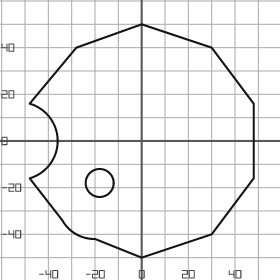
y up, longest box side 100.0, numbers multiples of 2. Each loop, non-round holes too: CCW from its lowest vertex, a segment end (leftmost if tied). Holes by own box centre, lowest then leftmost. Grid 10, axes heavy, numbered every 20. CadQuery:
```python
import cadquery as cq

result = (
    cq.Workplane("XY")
    .moveTo(0.0, -50.0)
    .lineTo(30.0, -40.0)
    .lineTo(48.0, -16.0)
    .lineTo(48.0, 16.0)
    .lineTo(30.0, 40.0)
    .lineTo(0.0, 50.0)
    .lineTo(-28.0, 40.0)
    .lineTo(-48.0, 16.0)
    .threePointArc((-36.0, 0.0), (-48.0, -16.0))
    .lineTo(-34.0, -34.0)
    .threePointArc((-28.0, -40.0), (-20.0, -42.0))
    .close()
    .moveTo(-18.0, -18.0)
    .circle(6.0)
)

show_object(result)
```